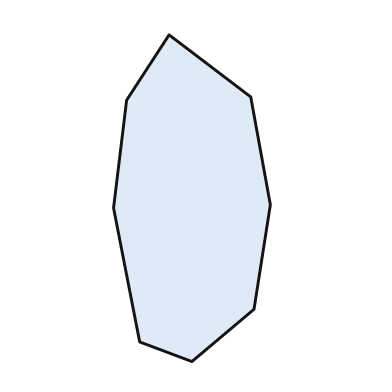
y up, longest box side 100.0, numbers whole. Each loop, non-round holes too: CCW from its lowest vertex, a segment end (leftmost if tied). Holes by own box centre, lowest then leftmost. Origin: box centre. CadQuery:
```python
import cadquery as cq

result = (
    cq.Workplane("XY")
    .moveTo(0.0, -50.0)
    .lineTo(19.0, -34.0)
    .lineTo(24.0, -2.0)
    .lineTo(18.0, 31.0)
    .lineTo(-7.0, 50.0)
    .lineTo(-20.0, 30.0)
    .lineTo(-24.0, -3.0)
    .lineTo(-16.0, -44.0)
    .close()
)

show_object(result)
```